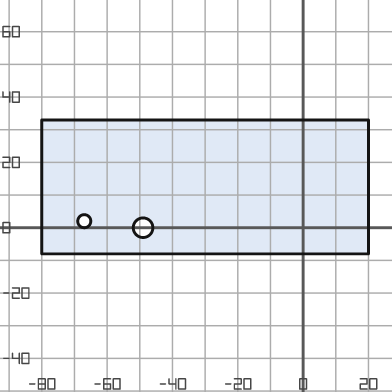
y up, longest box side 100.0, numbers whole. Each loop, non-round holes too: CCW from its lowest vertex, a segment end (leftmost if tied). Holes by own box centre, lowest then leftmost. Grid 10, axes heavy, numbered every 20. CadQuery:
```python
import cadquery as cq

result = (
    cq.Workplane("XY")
    .moveTo(-80.0, -8.0)
    .lineTo(20.0, -8.0)
    .lineTo(20.0, 33.0)
    .lineTo(-80.0, 33.0)
    .close()
    .moveTo(-49.0, 0.0)
    .circle(3.0)
    .moveTo(-67.0, 2.0)
    .circle(2.0)
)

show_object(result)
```